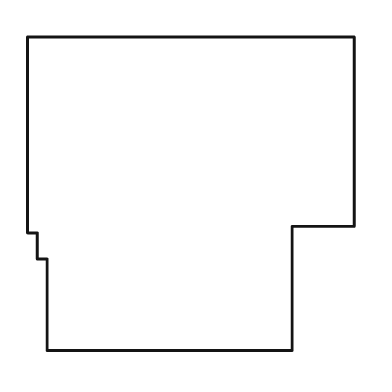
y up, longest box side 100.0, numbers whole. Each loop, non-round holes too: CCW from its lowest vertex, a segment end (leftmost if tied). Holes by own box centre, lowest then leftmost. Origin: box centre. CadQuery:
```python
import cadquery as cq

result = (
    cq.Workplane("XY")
    .moveTo(-44.0, -48.0)
    .lineTo(31.0, -48.0)
    .lineTo(31.0, -10.0)
    .lineTo(50.0, -10.0)
    .lineTo(50.0, 48.0)
    .lineTo(-50.0, 48.0)
    .lineTo(-50.0, -12.0)
    .lineTo(-47.0, -12.0)
    .lineTo(-47.0, -20.0)
    .lineTo(-44.0, -20.0)
    .close()
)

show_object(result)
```